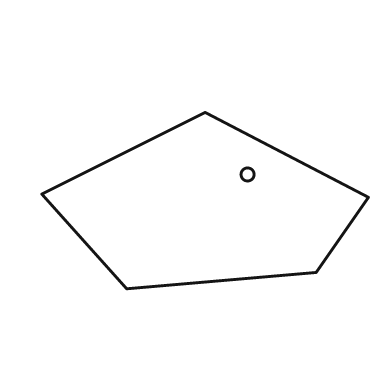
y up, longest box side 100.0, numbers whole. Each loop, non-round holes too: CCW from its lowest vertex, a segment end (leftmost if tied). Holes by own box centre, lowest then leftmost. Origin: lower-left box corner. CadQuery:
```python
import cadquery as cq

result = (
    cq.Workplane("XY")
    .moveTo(26.0, 0.0)
    .lineTo(84.0, 5.0)
    .lineTo(100.0, 28.0)
    .lineTo(50.0, 54.0)
    .lineTo(0.0, 29.0)
    .close()
    .moveTo(63.0, 35.0)
    .circle(2.0)
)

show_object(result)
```